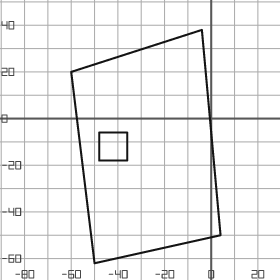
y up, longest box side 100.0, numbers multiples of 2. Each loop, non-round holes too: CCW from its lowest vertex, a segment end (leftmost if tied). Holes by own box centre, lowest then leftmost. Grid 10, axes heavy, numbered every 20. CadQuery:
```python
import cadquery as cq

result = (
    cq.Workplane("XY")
    .moveTo(-50.0, -62.0)
    .lineTo(4.0, -50.0)
    .lineTo(-4.0, 38.0)
    .lineTo(-60.0, 20.0)
    .close()
    .moveTo(-48.0, -18.0)
    .lineTo(-36.0, -18.0)
    .lineTo(-36.0, -6.0)
    .lineTo(-48.0, -6.0)
    .close()
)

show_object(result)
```